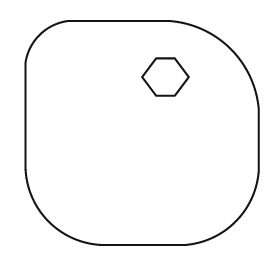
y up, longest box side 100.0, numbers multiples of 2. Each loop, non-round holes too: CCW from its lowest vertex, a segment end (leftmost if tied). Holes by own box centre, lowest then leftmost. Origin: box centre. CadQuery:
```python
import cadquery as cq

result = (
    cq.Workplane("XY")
    .moveTo(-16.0, -48.0)
    .lineTo(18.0, -48.0)
    .threePointArc((40.0, -38.0), (50.0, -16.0))
    .lineTo(50.0, 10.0)
    .threePointArc((38.0, 36.0), (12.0, 48.0))
    .lineTo(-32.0, 48.0)
    .threePointArc((-44.0, 42.0), (-50.0, 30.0))
    .lineTo(-50.0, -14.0)
    .threePointArc((-40.0, -38.0), (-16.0, -48.0))
    .close()
    .moveTo(6.0, 16.0)
    .lineTo(14.0, 16.0)
    .lineTo(20.0, 24.0)
    .lineTo(14.0, 32.0)
    .lineTo(6.0, 32.0)
    .lineTo(0.0, 24.0)
    .close()
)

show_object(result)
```